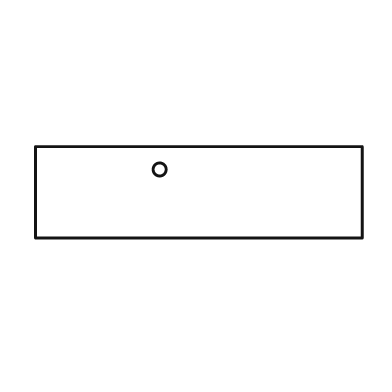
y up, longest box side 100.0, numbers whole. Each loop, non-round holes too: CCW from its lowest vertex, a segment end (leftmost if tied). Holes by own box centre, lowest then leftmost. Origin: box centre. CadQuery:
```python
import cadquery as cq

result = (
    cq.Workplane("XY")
    .moveTo(-50.0, -14.0)
    .lineTo(50.0, -14.0)
    .lineTo(50.0, 14.0)
    .lineTo(-50.0, 14.0)
    .close()
    .moveTo(-12.0, 7.0)
    .circle(2.0)
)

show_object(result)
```